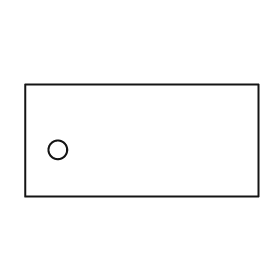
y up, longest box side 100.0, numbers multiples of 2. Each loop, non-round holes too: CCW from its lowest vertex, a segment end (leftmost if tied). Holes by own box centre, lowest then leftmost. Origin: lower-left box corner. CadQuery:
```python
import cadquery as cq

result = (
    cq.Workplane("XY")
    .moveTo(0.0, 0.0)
    .lineTo(100.0, 0.0)
    .lineTo(100.0, 48.0)
    .lineTo(0.0, 48.0)
    .close()
    .moveTo(14.0, 20.0)
    .circle(4.0)
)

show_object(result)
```